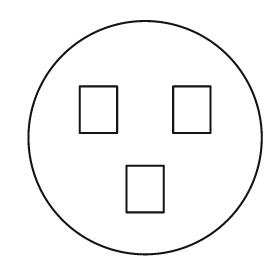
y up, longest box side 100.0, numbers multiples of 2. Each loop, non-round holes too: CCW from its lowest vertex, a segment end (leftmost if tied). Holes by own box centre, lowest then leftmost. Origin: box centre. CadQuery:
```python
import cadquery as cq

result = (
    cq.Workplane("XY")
    .moveTo(0.0, 0.0)
    .circle(50.0)
    .moveTo(-8.0, -32.0)
    .lineTo(8.0, -32.0)
    .lineTo(8.0, -12.0)
    .lineTo(-8.0, -12.0)
    .close()
    .moveTo(-28.0, 2.0)
    .lineTo(-12.0, 2.0)
    .lineTo(-12.0, 22.0)
    .lineTo(-28.0, 22.0)
    .close()
    .moveTo(12.0, 2.0)
    .lineTo(28.0, 2.0)
    .lineTo(28.0, 22.0)
    .lineTo(12.0, 22.0)
    .close()
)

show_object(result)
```